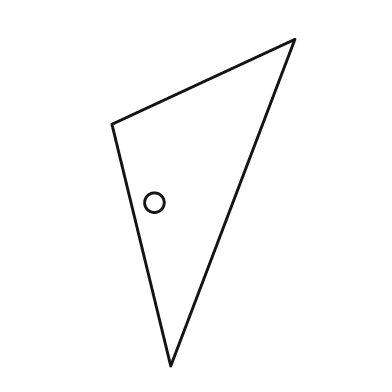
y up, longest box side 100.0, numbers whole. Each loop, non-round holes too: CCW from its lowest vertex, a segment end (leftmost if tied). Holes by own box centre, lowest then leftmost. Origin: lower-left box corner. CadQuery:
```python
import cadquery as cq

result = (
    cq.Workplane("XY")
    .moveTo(18.0, 0.0)
    .lineTo(56.0, 100.0)
    .lineTo(0.0, 74.0)
    .close()
    .moveTo(13.0, 50.0)
    .circle(3.0)
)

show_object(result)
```